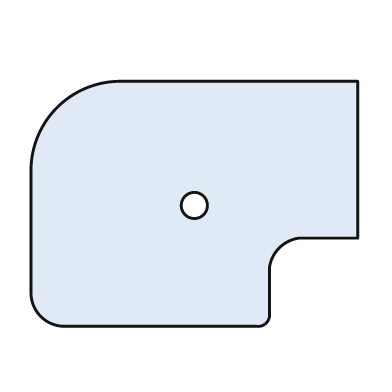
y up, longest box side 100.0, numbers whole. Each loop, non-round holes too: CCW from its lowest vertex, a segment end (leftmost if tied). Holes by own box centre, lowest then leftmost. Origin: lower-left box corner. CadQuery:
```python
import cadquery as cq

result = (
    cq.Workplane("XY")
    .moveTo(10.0, 0.0)
    .lineTo(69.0, 0.0)
    .threePointArc((72.0, 1.0), (73.0, 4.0))
    .lineTo(73.0, 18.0)
    .threePointArc((76.0, 24.0), (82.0, 27.0))
    .lineTo(100.0, 27.0)
    .lineTo(100.0, 75.0)
    .lineTo(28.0, 75.0)
    .threePointArc((8.0, 67.0), (0.0, 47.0))
    .lineTo(0.0, 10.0)
    .threePointArc((3.0, 3.0), (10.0, 0.0))
    .close()
    .moveTo(50.0, 37.0)
    .circle(4.0)
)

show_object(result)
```